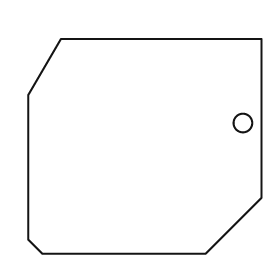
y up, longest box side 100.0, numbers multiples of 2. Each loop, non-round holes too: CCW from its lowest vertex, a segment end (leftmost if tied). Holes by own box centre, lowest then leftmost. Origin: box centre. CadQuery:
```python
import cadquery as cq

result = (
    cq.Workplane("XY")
    .moveTo(-44.0, -46.0)
    .lineTo(26.0, -46.0)
    .lineTo(50.0, -22.0)
    .lineTo(50.0, 46.0)
    .lineTo(-36.0, 46.0)
    .lineTo(-50.0, 22.0)
    .lineTo(-50.0, -40.0)
    .close()
    .moveTo(42.0, 10.0)
    .circle(4.0)
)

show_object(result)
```